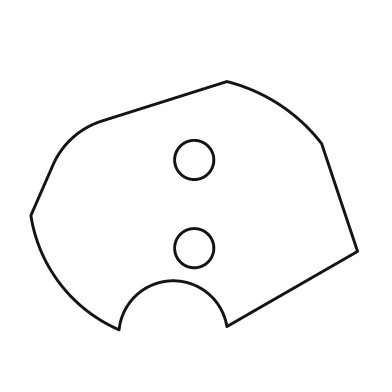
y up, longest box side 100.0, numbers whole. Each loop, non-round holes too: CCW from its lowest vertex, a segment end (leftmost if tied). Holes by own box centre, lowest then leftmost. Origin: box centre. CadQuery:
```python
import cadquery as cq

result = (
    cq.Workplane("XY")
    .moveTo(-23.0, -38.0)
    .threePointArc((-7.0, -23.0), (10.0, -37.0))
    .lineTo(50.0, -14.0)
    .lineTo(39.0, 19.0)
    .threePointArc((26.0, 31.0), (10.0, 38.0))
    .lineTo(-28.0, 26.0)
    .threePointArc((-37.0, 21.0), (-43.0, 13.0))
    .lineTo(-50.0, -3.0)
    .threePointArc((-41.0, -24.0), (-23.0, -38.0))
    .close()
    .moveTo(0.0, -13.0)
    .circle(6.0)
    .moveTo(0.0, 14.0)
    .circle(6.0)
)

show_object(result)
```